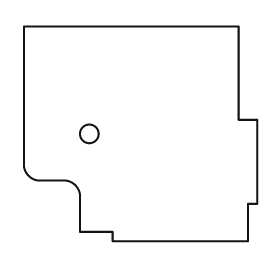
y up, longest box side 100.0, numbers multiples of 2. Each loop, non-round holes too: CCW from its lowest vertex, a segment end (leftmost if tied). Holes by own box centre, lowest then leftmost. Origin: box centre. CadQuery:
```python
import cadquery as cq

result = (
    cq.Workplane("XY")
    .moveTo(-12.0, -46.0)
    .lineTo(46.0, -46.0)
    .lineTo(46.0, -30.0)
    .lineTo(50.0, -30.0)
    .lineTo(50.0, 6.0)
    .lineTo(42.0, 6.0)
    .lineTo(42.0, 46.0)
    .lineTo(-50.0, 46.0)
    .lineTo(-50.0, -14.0)
    .threePointArc((-48.0, -18.0), (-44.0, -20.0))
    .lineTo(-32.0, -20.0)
    .threePointArc((-28.0, -22.0), (-26.0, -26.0))
    .lineTo(-26.0, -42.0)
    .lineTo(-12.0, -42.0)
    .close()
    .moveTo(-22.0, 0.0)
    .circle(4.0)
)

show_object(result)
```